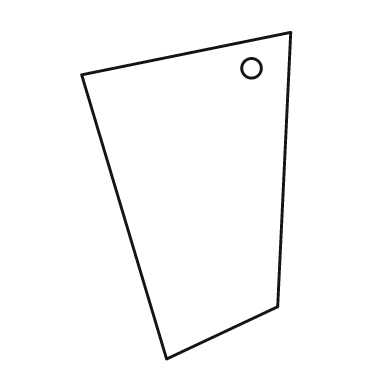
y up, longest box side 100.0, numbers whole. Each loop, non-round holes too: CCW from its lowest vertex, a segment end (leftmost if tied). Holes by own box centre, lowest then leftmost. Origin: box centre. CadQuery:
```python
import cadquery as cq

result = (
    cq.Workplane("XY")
    .moveTo(-6.0, -50.0)
    .lineTo(28.0, -34.0)
    .lineTo(32.0, 50.0)
    .lineTo(-32.0, 37.0)
    .close()
    .moveTo(20.0, 39.0)
    .circle(3.0)
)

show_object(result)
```